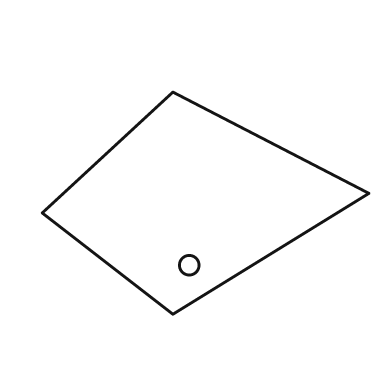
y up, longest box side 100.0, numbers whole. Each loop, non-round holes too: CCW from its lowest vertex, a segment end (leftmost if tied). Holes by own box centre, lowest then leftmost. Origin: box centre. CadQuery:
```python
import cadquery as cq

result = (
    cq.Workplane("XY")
    .moveTo(-10.0, -34.0)
    .lineTo(50.0, 3.0)
    .lineTo(-10.0, 34.0)
    .lineTo(-50.0, -3.0)
    .close()
    .moveTo(-5.0, -19.0)
    .circle(3.0)
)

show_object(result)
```